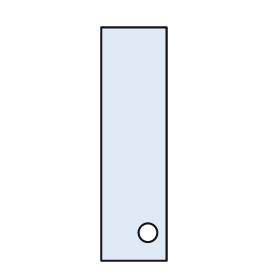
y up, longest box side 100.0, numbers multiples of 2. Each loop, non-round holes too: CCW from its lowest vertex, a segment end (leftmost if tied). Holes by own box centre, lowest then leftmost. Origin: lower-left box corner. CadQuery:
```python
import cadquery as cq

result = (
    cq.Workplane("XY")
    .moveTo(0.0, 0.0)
    .lineTo(28.0, 0.0)
    .lineTo(28.0, 100.0)
    .lineTo(0.0, 100.0)
    .close()
    .moveTo(20.0, 12.0)
    .circle(4.0)
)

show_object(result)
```